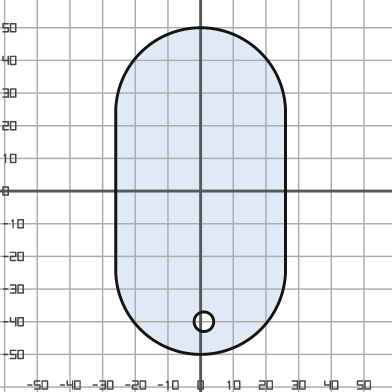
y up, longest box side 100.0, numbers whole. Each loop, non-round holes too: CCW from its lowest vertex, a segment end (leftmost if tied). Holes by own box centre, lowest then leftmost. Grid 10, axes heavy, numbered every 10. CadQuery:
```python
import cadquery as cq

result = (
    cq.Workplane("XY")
    .moveTo(-26.0, -24.0)
    .threePointArc((0.0, -50.0), (26.0, -24.0))
    .lineTo(26.0, 24.0)
    .threePointArc((0.0, 50.0), (-26.0, 24.0))
    .close()
    .moveTo(1.0, -40.0)
    .circle(3.0)
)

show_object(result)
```